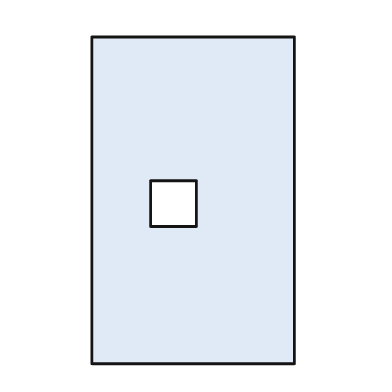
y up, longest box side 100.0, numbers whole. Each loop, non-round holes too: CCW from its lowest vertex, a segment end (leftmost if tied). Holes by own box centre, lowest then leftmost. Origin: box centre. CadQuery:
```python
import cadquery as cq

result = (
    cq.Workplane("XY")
    .moveTo(-31.0, -50.0)
    .lineTo(31.0, -50.0)
    .lineTo(31.0, 50.0)
    .lineTo(-31.0, 50.0)
    .close()
    .moveTo(-13.0, -8.0)
    .lineTo(1.0, -8.0)
    .lineTo(1.0, 6.0)
    .lineTo(-13.0, 6.0)
    .close()
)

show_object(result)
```